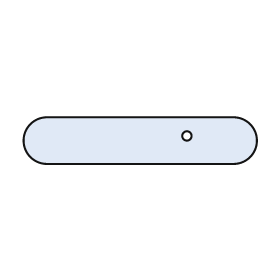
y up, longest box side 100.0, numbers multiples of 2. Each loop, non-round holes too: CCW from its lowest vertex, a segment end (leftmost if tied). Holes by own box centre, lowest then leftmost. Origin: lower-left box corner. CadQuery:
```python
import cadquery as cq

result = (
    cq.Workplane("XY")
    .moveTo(10.0, 0.0)
    .lineTo(90.0, 0.0)
    .threePointArc((100.0, 10.0), (90.0, 20.0))
    .lineTo(10.0, 20.0)
    .threePointArc((0.0, 10.0), (10.0, 0.0))
    .close()
    .moveTo(70.0, 12.0)
    .circle(2.0)
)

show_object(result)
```